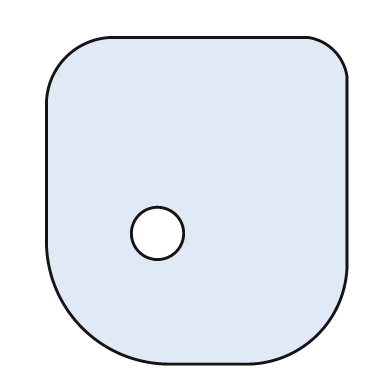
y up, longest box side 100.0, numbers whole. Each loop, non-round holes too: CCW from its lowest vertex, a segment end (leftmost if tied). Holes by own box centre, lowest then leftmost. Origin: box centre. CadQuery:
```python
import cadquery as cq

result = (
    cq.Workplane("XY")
    .moveTo(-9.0, -50.0)
    .lineTo(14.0, -50.0)
    .threePointArc((37.0, -41.0), (46.0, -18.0))
    .lineTo(46.0, 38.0)
    .threePointArc((42.0, 46.0), (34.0, 50.0))
    .lineTo(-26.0, 50.0)
    .threePointArc((-40.0, 44.0), (-46.0, 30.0))
    .lineTo(-46.0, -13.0)
    .threePointArc((-35.0, -39.0), (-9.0, -50.0))
    .close()
    .moveTo(-12.0, -10.0)
    .circle(8.0)
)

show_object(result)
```